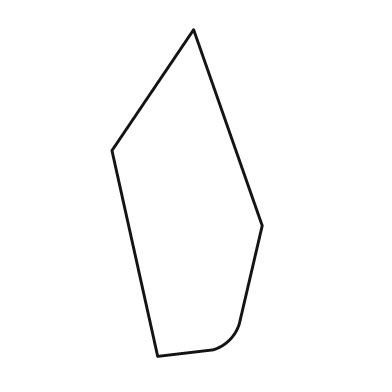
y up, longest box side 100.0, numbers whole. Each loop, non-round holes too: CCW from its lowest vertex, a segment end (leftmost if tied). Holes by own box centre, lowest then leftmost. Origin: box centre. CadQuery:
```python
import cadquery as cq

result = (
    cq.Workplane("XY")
    .moveTo(-9.0, -50.0)
    .lineTo(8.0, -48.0)
    .threePointArc((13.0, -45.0), (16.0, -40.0))
    .lineTo(23.0, -10.0)
    .lineTo(2.0, 50.0)
    .lineTo(-23.0, 13.0)
    .close()
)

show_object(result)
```